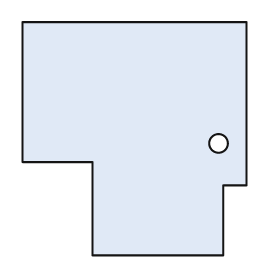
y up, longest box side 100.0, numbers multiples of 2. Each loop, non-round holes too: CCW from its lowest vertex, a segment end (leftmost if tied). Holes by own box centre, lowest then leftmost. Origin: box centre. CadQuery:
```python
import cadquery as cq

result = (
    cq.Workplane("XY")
    .moveTo(-18.0, -50.0)
    .lineTo(38.0, -50.0)
    .lineTo(38.0, -20.0)
    .lineTo(48.0, -20.0)
    .lineTo(48.0, 50.0)
    .lineTo(-48.0, 50.0)
    .lineTo(-48.0, -10.0)
    .lineTo(-18.0, -10.0)
    .close()
    .moveTo(36.0, -2.0)
    .circle(4.0)
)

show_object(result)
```